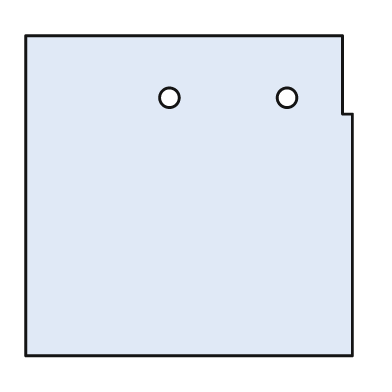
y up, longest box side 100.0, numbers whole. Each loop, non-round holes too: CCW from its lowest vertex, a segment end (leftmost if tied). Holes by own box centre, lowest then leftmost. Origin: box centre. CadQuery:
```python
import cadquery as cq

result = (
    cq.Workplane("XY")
    .moveTo(-50.0, -49.0)
    .lineTo(50.0, -49.0)
    .lineTo(50.0, 25.0)
    .lineTo(47.0, 25.0)
    .lineTo(47.0, 49.0)
    .lineTo(-50.0, 49.0)
    .close()
    .moveTo(-6.0, 30.0)
    .circle(3.0)
    .moveTo(30.0, 30.0)
    .circle(3.0)
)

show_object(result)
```